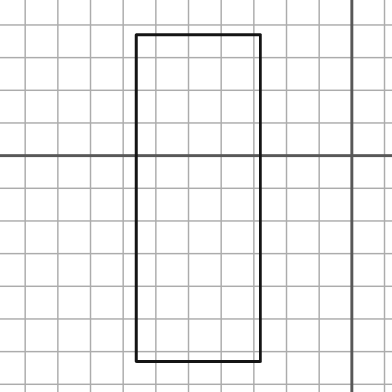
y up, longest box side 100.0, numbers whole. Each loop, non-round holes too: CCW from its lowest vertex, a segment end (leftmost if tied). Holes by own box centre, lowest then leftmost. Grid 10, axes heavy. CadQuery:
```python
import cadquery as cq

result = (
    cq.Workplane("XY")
    .moveTo(-66.0, -63.0)
    .lineTo(-28.0, -63.0)
    .lineTo(-28.0, 37.0)
    .lineTo(-66.0, 37.0)
    .close()
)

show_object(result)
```